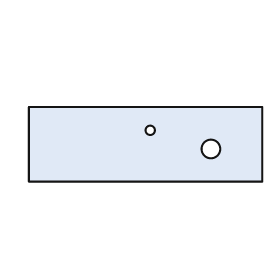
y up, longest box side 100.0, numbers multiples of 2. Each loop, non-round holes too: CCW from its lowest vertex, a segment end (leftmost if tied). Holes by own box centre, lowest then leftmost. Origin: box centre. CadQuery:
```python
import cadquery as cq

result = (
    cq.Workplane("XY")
    .moveTo(-50.0, -16.0)
    .lineTo(50.0, -16.0)
    .lineTo(50.0, 16.0)
    .lineTo(-50.0, 16.0)
    .close()
    .moveTo(28.0, -2.0)
    .circle(4.0)
    .moveTo(2.0, 6.0)
    .circle(2.0)
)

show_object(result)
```